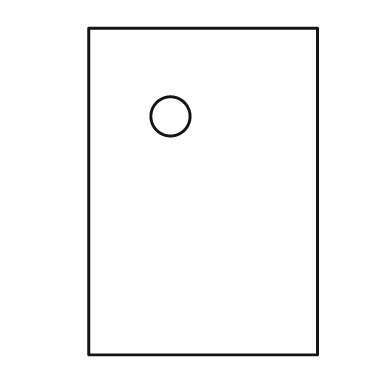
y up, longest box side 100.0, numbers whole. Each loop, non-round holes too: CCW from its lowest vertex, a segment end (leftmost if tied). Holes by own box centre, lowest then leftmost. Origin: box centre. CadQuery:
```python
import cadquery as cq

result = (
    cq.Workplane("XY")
    .moveTo(-35.0, -50.0)
    .lineTo(35.0, -50.0)
    .lineTo(35.0, 50.0)
    .lineTo(-35.0, 50.0)
    .close()
    .moveTo(-10.0, 23.0)
    .circle(6.0)
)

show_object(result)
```